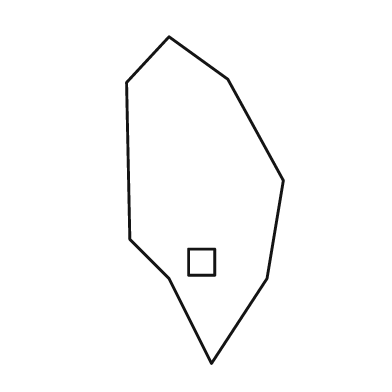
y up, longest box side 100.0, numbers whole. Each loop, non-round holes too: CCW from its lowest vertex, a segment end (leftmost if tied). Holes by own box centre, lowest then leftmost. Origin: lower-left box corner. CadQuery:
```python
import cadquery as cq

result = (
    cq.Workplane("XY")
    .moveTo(26.0, 0.0)
    .lineTo(43.0, 26.0)
    .lineTo(48.0, 56.0)
    .lineTo(31.0, 87.0)
    .lineTo(13.0, 100.0)
    .lineTo(0.0, 86.0)
    .lineTo(1.0, 38.0)
    .lineTo(13.0, 26.0)
    .close()
    .moveTo(19.0, 27.0)
    .lineTo(27.0, 27.0)
    .lineTo(27.0, 35.0)
    .lineTo(19.0, 35.0)
    .close()
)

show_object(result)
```